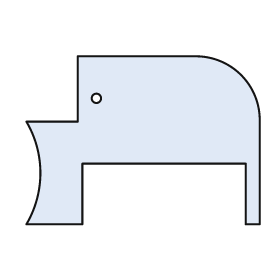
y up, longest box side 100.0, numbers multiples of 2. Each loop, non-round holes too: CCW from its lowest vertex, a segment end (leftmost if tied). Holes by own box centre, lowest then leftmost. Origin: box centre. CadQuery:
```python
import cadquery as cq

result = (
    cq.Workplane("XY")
    .moveTo(-50.0, -36.0)
    .lineTo(-26.0, -36.0)
    .lineTo(-26.0, -10.0)
    .lineTo(44.0, -10.0)
    .lineTo(44.0, -36.0)
    .lineTo(50.0, -36.0)
    .lineTo(50.0, 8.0)
    .threePointArc((42.0, 28.0), (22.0, 36.0))
    .lineTo(-28.0, 36.0)
    .lineTo(-28.0, 8.0)
    .lineTo(-50.0, 8.0)
    .threePointArc((-44.0, -14.0), (-50.0, -36.0))
    .close()
    .moveTo(-20.0, 18.0)
    .circle(2.0)
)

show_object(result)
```